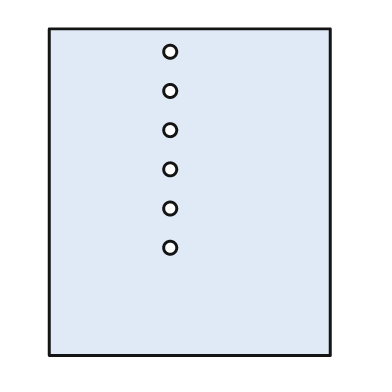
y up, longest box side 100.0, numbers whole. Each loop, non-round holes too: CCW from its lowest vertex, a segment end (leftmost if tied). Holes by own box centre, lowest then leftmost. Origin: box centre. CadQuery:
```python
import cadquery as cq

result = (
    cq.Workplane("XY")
    .moveTo(-43.0, -50.0)
    .lineTo(43.0, -50.0)
    .lineTo(43.0, 50.0)
    .lineTo(-43.0, 50.0)
    .close()
    .moveTo(-6.0, -17.0)
    .circle(2.0)
    .moveTo(-6.0, -5.0)
    .circle(2.0)
    .moveTo(-6.0, 7.0)
    .circle(2.0)
    .moveTo(-6.0, 19.0)
    .circle(2.0)
    .moveTo(-6.0, 31.0)
    .circle(2.0)
    .moveTo(-6.0, 43.0)
    .circle(2.0)
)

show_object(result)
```